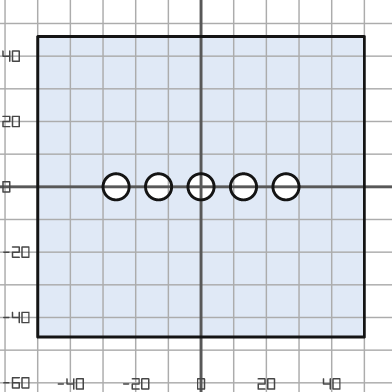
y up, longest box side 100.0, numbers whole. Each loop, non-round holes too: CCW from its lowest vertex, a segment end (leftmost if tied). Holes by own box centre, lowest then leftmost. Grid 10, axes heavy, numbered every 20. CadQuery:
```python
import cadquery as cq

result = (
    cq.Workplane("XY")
    .moveTo(-50.0, -46.0)
    .lineTo(50.0, -46.0)
    .lineTo(50.0, 46.0)
    .lineTo(-50.0, 46.0)
    .close()
    .moveTo(-26.0, 0.0)
    .circle(4.0)
    .moveTo(-13.0, 0.0)
    .circle(4.0)
    .moveTo(0.0, 0.0)
    .circle(4.0)
    .moveTo(13.0, 0.0)
    .circle(4.0)
    .moveTo(26.0, 0.0)
    .circle(4.0)
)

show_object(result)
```